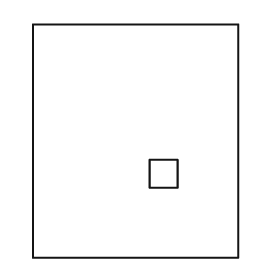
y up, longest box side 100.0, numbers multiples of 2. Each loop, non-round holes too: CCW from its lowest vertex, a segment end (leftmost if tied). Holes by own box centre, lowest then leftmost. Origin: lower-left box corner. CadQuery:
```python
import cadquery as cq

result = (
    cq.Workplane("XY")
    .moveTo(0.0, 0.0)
    .lineTo(88.0, 0.0)
    .lineTo(88.0, 100.0)
    .lineTo(0.0, 100.0)
    .close()
    .moveTo(50.0, 30.0)
    .lineTo(62.0, 30.0)
    .lineTo(62.0, 42.0)
    .lineTo(50.0, 42.0)
    .close()
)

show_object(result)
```